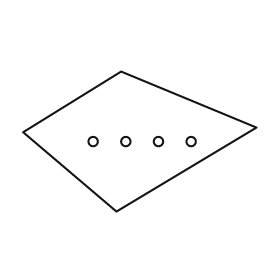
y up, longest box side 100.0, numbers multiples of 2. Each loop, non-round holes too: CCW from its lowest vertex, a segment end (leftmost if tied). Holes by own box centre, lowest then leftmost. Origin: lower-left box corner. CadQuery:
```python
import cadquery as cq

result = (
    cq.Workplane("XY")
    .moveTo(40.0, 0.0)
    .lineTo(100.0, 36.0)
    .lineTo(42.0, 60.0)
    .lineTo(0.0, 34.0)
    .close()
    .moveTo(30.0, 30.0)
    .circle(2.0)
    .moveTo(44.0, 30.0)
    .circle(2.0)
    .moveTo(58.0, 30.0)
    .circle(2.0)
    .moveTo(72.0, 30.0)
    .circle(2.0)
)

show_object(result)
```